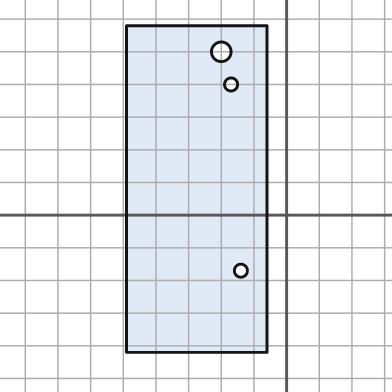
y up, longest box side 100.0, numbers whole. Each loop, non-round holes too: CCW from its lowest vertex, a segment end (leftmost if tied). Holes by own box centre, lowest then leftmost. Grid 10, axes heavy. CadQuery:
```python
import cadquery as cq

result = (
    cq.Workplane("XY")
    .moveTo(-49.0, -42.0)
    .lineTo(-6.0, -42.0)
    .lineTo(-6.0, 58.0)
    .lineTo(-49.0, 58.0)
    .close()
    .moveTo(-14.0, -17.0)
    .circle(2.0)
    .moveTo(-17.0, 40.0)
    .circle(2.0)
    .moveTo(-20.0, 50.0)
    .circle(3.0)
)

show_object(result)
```